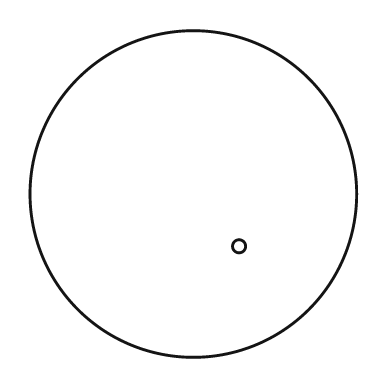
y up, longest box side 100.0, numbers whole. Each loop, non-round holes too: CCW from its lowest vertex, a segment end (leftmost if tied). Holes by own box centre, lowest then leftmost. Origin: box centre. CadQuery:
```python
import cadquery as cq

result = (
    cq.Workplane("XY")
    .moveTo(0.0, 0.0)
    .circle(50.0)
    .moveTo(14.0, -16.0)
    .circle(2.0)
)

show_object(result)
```